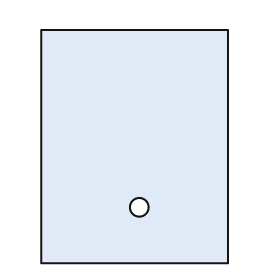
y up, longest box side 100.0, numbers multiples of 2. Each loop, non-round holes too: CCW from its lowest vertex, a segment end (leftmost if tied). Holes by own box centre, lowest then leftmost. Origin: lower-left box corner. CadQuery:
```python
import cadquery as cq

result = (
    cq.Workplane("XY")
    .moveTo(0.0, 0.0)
    .lineTo(80.0, 0.0)
    .lineTo(80.0, 100.0)
    .lineTo(0.0, 100.0)
    .close()
    .moveTo(42.0, 24.0)
    .circle(4.0)
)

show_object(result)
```